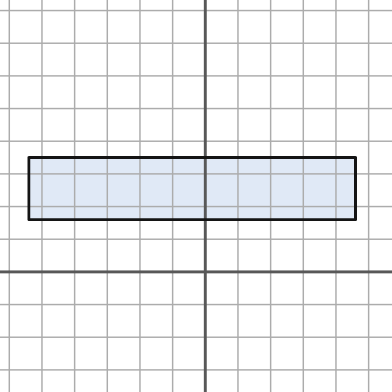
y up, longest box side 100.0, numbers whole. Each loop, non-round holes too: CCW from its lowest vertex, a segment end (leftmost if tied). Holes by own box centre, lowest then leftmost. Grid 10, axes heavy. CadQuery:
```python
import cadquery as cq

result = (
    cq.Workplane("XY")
    .moveTo(-54.0, 16.0)
    .lineTo(46.0, 16.0)
    .lineTo(46.0, 35.0)
    .lineTo(-54.0, 35.0)
    .close()
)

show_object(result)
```